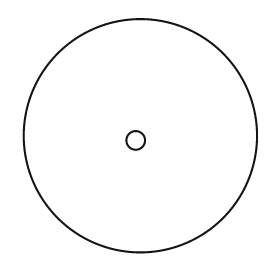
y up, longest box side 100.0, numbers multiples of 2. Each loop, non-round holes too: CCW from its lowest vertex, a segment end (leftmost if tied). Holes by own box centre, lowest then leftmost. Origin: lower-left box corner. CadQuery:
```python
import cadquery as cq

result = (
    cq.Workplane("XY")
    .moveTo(50.0, 50.0)
    .circle(50.0)
    .moveTo(48.0, 48.0)
    .circle(4.0)
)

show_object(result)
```